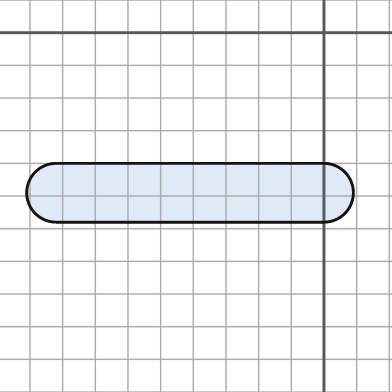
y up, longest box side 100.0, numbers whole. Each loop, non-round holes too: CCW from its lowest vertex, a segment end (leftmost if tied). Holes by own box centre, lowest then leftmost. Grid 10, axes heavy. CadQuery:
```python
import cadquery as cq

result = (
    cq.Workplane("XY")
    .moveTo(-82.0, -58.0)
    .lineTo(0.0, -58.0)
    .threePointArc((9.0, -49.0), (0.0, -40.0))
    .lineTo(-82.0, -40.0)
    .threePointArc((-91.0, -49.0), (-82.0, -58.0))
    .close()
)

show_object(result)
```